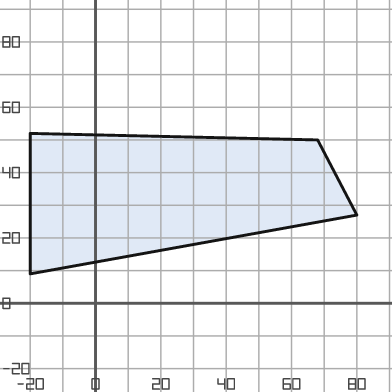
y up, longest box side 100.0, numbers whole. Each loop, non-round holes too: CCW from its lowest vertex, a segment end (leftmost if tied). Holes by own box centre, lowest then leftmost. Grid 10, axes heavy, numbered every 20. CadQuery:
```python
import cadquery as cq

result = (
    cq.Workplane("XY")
    .moveTo(-20.0, 9.0)
    .lineTo(80.0, 27.0)
    .lineTo(68.0, 50.0)
    .lineTo(-20.0, 52.0)
    .close()
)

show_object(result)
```